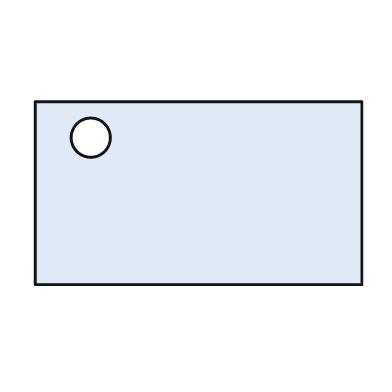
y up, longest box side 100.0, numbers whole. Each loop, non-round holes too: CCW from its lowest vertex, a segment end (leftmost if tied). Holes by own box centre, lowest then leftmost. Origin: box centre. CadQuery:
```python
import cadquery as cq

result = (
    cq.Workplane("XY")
    .moveTo(-50.0, -28.0)
    .lineTo(50.0, -28.0)
    .lineTo(50.0, 28.0)
    .lineTo(-50.0, 28.0)
    .close()
    .moveTo(-33.0, 17.0)
    .circle(6.0)
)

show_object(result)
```